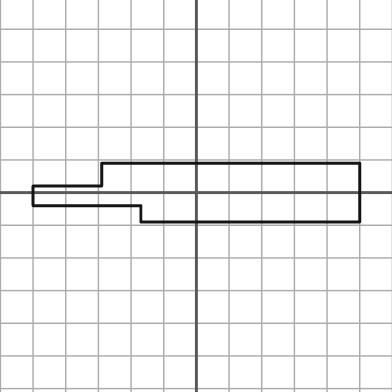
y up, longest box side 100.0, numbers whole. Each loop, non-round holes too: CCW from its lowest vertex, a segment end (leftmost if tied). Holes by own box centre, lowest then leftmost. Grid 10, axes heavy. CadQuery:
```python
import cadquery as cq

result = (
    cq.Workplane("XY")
    .moveTo(-17.0, -9.0)
    .lineTo(50.0, -9.0)
    .lineTo(50.0, 9.0)
    .lineTo(-29.0, 9.0)
    .lineTo(-29.0, 2.0)
    .lineTo(-50.0, 2.0)
    .lineTo(-50.0, -4.0)
    .lineTo(-17.0, -4.0)
    .close()
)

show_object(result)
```